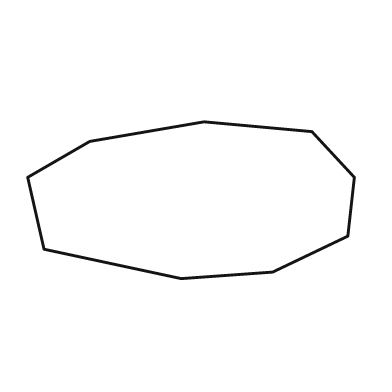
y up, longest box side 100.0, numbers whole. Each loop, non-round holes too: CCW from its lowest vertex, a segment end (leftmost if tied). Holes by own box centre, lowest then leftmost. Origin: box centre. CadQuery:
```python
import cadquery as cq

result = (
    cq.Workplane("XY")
    .moveTo(-3.0, -24.0)
    .lineTo(25.0, -22.0)
    .lineTo(48.0, -11.0)
    .lineTo(50.0, 7.0)
    .lineTo(37.0, 21.0)
    .lineTo(4.0, 24.0)
    .lineTo(-31.0, 18.0)
    .lineTo(-50.0, 7.0)
    .lineTo(-45.0, -15.0)
    .close()
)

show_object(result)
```